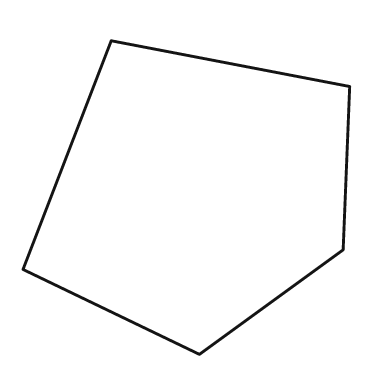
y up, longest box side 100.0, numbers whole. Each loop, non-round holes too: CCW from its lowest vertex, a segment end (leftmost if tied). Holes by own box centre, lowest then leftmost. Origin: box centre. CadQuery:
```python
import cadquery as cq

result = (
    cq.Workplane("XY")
    .moveTo(4.0, -48.0)
    .lineTo(48.0, -16.0)
    .lineTo(50.0, 34.0)
    .lineTo(-23.0, 48.0)
    .lineTo(-50.0, -22.0)
    .close()
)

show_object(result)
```